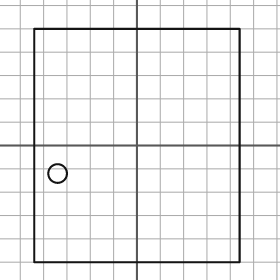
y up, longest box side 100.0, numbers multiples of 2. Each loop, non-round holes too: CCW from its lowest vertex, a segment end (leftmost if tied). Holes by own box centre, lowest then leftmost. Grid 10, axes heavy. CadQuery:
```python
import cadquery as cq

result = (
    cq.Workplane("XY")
    .moveTo(-44.0, -50.0)
    .lineTo(44.0, -50.0)
    .lineTo(44.0, 50.0)
    .lineTo(-44.0, 50.0)
    .close()
    .moveTo(-34.0, -12.0)
    .circle(4.0)
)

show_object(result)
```